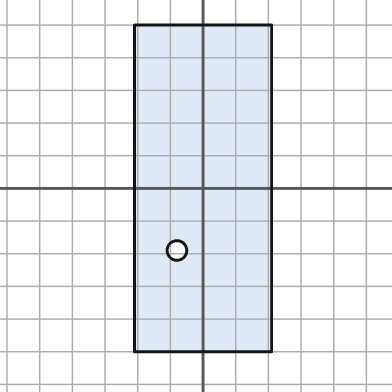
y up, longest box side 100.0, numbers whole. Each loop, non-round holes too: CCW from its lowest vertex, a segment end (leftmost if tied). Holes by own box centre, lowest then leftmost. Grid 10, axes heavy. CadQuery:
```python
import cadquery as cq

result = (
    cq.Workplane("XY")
    .moveTo(-21.0, -50.0)
    .lineTo(21.0, -50.0)
    .lineTo(21.0, 50.0)
    .lineTo(-21.0, 50.0)
    .close()
    .moveTo(-8.0, -19.0)
    .circle(3.0)
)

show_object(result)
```